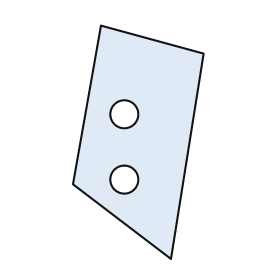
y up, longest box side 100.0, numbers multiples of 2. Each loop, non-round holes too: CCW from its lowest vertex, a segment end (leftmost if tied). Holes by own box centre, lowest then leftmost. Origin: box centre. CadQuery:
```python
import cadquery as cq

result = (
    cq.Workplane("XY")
    .moveTo(14.0, -50.0)
    .lineTo(28.0, 38.0)
    .lineTo(-16.0, 50.0)
    .lineTo(-28.0, -18.0)
    .close()
    .moveTo(-6.0, -16.0)
    .circle(6.0)
    .moveTo(-6.0, 12.0)
    .circle(6.0)
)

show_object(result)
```